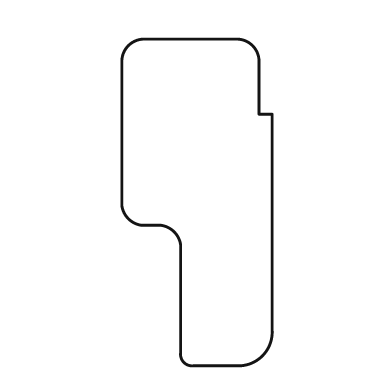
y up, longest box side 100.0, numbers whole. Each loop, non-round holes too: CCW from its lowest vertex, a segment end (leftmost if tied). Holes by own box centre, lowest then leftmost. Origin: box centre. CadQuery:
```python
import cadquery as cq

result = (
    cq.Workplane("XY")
    .moveTo(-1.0, -50.0)
    .lineTo(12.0, -50.0)
    .threePointArc((20.0, -47.0), (23.0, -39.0))
    .lineTo(23.0, 27.0)
    .lineTo(19.0, 27.0)
    .lineTo(19.0, 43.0)
    .threePointArc((17.0, 48.0), (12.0, 50.0))
    .lineTo(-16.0, 50.0)
    .threePointArc((-21.0, 48.0), (-23.0, 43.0))
    .lineTo(-23.0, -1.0)
    .threePointArc((-21.0, -5.0), (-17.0, -7.0))
    .lineTo(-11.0, -7.0)
    .threePointArc((-7.0, -9.0), (-5.0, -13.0))
    .lineTo(-5.0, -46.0)
    .threePointArc((-4.0, -49.0), (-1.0, -50.0))
    .close()
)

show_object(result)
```